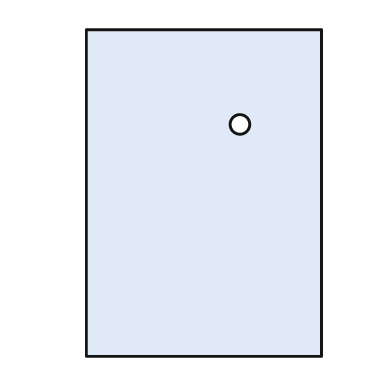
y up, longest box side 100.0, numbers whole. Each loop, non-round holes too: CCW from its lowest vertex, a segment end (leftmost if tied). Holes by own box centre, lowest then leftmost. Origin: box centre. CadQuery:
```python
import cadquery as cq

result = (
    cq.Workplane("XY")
    .moveTo(-36.0, -50.0)
    .lineTo(36.0, -50.0)
    .lineTo(36.0, 50.0)
    .lineTo(-36.0, 50.0)
    .close()
    .moveTo(11.0, 21.0)
    .circle(3.0)
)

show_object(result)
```